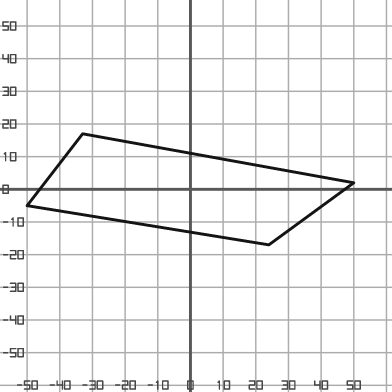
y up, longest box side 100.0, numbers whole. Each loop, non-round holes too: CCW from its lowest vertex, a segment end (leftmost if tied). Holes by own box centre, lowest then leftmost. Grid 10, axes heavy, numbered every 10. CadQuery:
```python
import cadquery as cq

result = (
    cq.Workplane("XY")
    .moveTo(24.0, -17.0)
    .lineTo(50.0, 2.0)
    .lineTo(-33.0, 17.0)
    .lineTo(-50.0, -5.0)
    .close()
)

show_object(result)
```